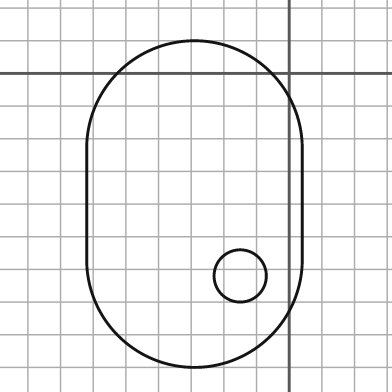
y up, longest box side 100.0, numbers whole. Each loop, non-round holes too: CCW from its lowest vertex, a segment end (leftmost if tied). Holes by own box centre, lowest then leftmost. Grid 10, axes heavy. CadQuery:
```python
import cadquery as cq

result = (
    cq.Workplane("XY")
    .moveTo(-62.0, -57.0)
    .threePointArc((-29.0, -90.0), (4.0, -57.0))
    .lineTo(4.0, -23.0)
    .threePointArc((-29.0, 10.0), (-62.0, -23.0))
    .close()
    .moveTo(-15.0, -62.0)
    .circle(8.0)
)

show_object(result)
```